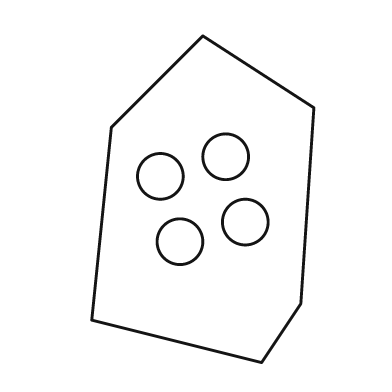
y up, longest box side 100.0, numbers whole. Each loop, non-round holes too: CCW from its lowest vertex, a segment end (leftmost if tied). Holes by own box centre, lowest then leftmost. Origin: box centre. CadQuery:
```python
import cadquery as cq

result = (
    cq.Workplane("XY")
    .moveTo(18.0, -50.0)
    .lineTo(30.0, -32.0)
    .lineTo(34.0, 28.0)
    .lineTo(0.0, 50.0)
    .lineTo(-28.0, 22.0)
    .lineTo(-34.0, -37.0)
    .close()
    .moveTo(-7.0, -13.0)
    .circle(7.0)
    .moveTo(13.0, -7.0)
    .circle(7.0)
    .moveTo(-13.0, 7.0)
    .circle(7.0)
    .moveTo(7.0, 13.0)
    .circle(7.0)
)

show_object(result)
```